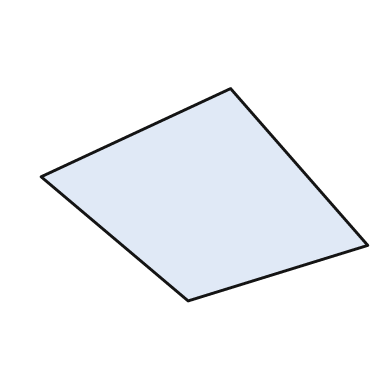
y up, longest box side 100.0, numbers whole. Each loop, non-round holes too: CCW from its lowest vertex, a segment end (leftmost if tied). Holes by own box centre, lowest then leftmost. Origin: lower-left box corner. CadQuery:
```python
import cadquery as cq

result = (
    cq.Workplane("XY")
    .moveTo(45.0, 0.0)
    .lineTo(100.0, 17.0)
    .lineTo(58.0, 65.0)
    .lineTo(0.0, 38.0)
    .close()
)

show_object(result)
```